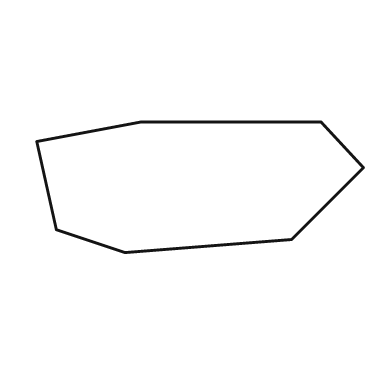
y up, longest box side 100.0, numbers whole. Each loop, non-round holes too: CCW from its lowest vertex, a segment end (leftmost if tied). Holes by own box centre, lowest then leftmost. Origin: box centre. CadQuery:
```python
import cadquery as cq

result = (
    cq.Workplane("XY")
    .moveTo(-23.0, -20.0)
    .lineTo(28.0, -16.0)
    .lineTo(50.0, 6.0)
    .lineTo(37.0, 20.0)
    .lineTo(-18.0, 20.0)
    .lineTo(-50.0, 14.0)
    .lineTo(-44.0, -13.0)
    .close()
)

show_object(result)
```